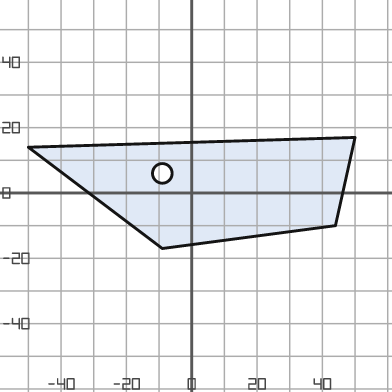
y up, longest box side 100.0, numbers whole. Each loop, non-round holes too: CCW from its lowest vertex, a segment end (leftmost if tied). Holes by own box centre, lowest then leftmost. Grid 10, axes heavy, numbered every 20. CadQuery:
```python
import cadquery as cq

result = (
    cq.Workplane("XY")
    .moveTo(-9.0, -17.0)
    .lineTo(44.0, -10.0)
    .lineTo(50.0, 17.0)
    .lineTo(-50.0, 14.0)
    .close()
    .moveTo(-9.0, 6.0)
    .circle(3.0)
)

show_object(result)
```